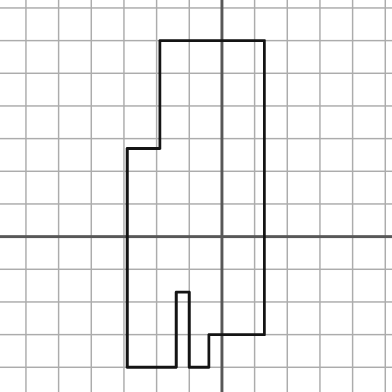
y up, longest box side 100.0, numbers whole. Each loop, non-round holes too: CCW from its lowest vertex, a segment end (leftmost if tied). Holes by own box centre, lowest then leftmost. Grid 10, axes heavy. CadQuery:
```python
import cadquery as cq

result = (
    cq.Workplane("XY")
    .moveTo(-29.0, -40.0)
    .lineTo(-14.0, -40.0)
    .lineTo(-14.0, -17.0)
    .lineTo(-10.0, -17.0)
    .lineTo(-10.0, -40.0)
    .lineTo(-4.0, -40.0)
    .lineTo(-4.0, -30.0)
    .lineTo(13.0, -30.0)
    .lineTo(13.0, 60.0)
    .lineTo(-19.0, 60.0)
    .lineTo(-19.0, 27.0)
    .lineTo(-29.0, 27.0)
    .close()
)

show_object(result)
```